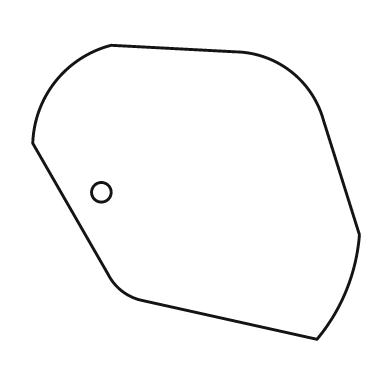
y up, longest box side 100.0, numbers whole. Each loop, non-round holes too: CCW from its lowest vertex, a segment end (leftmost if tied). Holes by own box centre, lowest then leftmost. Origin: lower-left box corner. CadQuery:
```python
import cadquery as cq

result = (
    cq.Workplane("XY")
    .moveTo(87.0, 0.0)
    .threePointArc((96.0, 15.0), (100.0, 32.0))
    .lineTo(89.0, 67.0)
    .threePointArc((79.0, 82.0), (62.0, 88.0))
    .lineTo(24.0, 90.0)
    .threePointArc((7.0, 79.0), (0.0, 60.0))
    .lineTo(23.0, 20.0)
    .threePointArc((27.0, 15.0), (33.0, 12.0))
    .close()
    .moveTo(21.0, 45.0)
    .circle(3.0)
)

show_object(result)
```